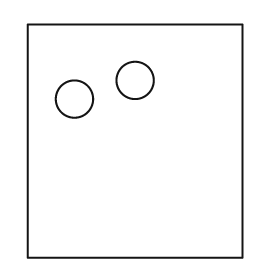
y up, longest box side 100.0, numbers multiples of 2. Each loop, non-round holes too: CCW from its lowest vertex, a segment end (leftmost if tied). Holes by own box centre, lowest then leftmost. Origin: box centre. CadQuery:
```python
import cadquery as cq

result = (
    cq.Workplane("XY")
    .moveTo(-46.0, -50.0)
    .lineTo(46.0, -50.0)
    .lineTo(46.0, 50.0)
    .lineTo(-46.0, 50.0)
    .close()
    .moveTo(-26.0, 18.0)
    .circle(8.0)
    .moveTo(0.0, 26.0)
    .circle(8.0)
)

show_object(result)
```